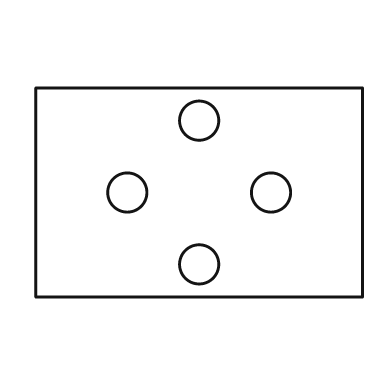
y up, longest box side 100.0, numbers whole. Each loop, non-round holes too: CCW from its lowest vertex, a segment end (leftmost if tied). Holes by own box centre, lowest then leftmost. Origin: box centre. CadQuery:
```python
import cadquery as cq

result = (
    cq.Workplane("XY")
    .moveTo(-50.0, -32.0)
    .lineTo(50.0, -32.0)
    .lineTo(50.0, 32.0)
    .lineTo(-50.0, 32.0)
    .close()
    .moveTo(0.0, -22.0)
    .circle(6.0)
    .moveTo(-22.0, 0.0)
    .circle(6.0)
    .moveTo(22.0, 0.0)
    .circle(6.0)
    .moveTo(0.0, 22.0)
    .circle(6.0)
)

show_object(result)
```